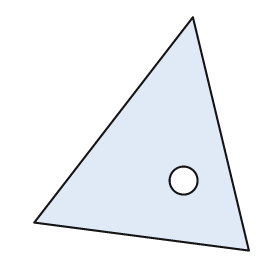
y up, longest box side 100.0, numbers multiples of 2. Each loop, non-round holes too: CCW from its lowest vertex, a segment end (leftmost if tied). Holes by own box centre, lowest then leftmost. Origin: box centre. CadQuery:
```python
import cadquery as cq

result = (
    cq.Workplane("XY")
    .moveTo(46.0, -50.0)
    .lineTo(22.0, 50.0)
    .lineTo(-46.0, -38.0)
    .close()
    .moveTo(18.0, -20.0)
    .circle(6.0)
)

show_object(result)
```